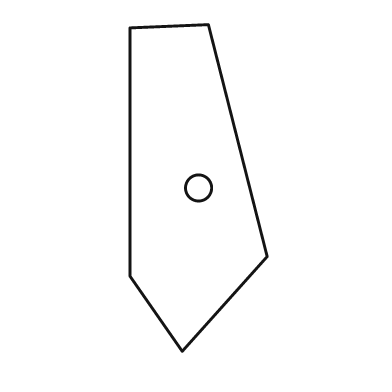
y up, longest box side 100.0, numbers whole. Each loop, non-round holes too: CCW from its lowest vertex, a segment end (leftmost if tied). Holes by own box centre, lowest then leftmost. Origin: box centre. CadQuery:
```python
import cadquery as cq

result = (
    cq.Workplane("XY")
    .moveTo(-5.0, -50.0)
    .lineTo(21.0, -21.0)
    .lineTo(3.0, 50.0)
    .lineTo(-21.0, 49.0)
    .lineTo(-21.0, -27.0)
    .close()
    .moveTo(0.0, 0.0)
    .circle(4.0)
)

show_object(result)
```